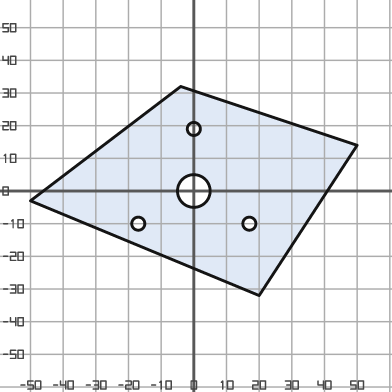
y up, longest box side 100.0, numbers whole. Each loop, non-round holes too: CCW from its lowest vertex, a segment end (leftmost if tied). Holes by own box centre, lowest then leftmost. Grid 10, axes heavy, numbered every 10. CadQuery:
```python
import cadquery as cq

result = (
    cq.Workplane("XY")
    .moveTo(20.0, -32.0)
    .lineTo(50.0, 14.0)
    .lineTo(-4.0, 32.0)
    .lineTo(-50.0, -3.0)
    .close()
    .moveTo(-17.0, -10.0)
    .circle(2.0)
    .moveTo(17.0, -10.0)
    .circle(2.0)
    .moveTo(0.0, 0.0)
    .circle(5.0)
    .moveTo(0.0, 19.0)
    .circle(2.0)
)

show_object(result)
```